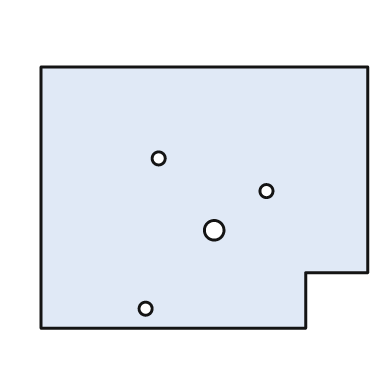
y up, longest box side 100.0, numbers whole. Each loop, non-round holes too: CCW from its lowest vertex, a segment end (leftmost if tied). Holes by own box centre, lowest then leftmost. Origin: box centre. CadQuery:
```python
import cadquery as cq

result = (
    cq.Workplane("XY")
    .moveTo(-50.0, -40.0)
    .lineTo(31.0, -40.0)
    .lineTo(31.0, -23.0)
    .lineTo(50.0, -23.0)
    .lineTo(50.0, 40.0)
    .lineTo(-50.0, 40.0)
    .close()
    .moveTo(-18.0, -34.0)
    .circle(2.0)
    .moveTo(3.0, -10.0)
    .circle(3.0)
    .moveTo(19.0, 2.0)
    .circle(2.0)
    .moveTo(-14.0, 12.0)
    .circle(2.0)
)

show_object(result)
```